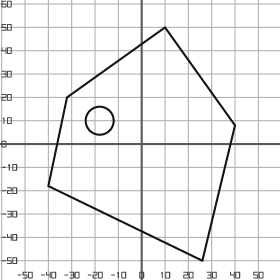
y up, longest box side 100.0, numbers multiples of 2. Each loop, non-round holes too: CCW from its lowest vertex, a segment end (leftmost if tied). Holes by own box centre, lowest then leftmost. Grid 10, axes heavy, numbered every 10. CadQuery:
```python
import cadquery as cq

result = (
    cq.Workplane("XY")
    .moveTo(26.0, -50.0)
    .lineTo(40.0, 8.0)
    .lineTo(10.0, 50.0)
    .lineTo(-32.0, 20.0)
    .lineTo(-40.0, -18.0)
    .close()
    .moveTo(-18.0, 10.0)
    .circle(6.0)
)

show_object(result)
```